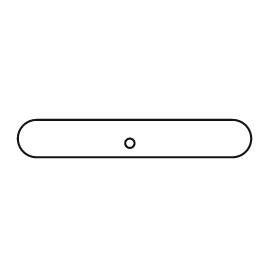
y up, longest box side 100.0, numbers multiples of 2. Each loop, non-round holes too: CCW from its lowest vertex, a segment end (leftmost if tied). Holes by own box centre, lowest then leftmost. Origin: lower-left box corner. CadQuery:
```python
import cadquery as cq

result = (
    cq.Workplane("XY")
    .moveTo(8.0, 0.0)
    .lineTo(92.0, 0.0)
    .threePointArc((100.0, 8.0), (92.0, 16.0))
    .lineTo(8.0, 16.0)
    .threePointArc((0.0, 8.0), (8.0, 0.0))
    .close()
    .moveTo(48.0, 6.0)
    .circle(2.0)
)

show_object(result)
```